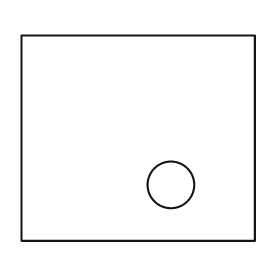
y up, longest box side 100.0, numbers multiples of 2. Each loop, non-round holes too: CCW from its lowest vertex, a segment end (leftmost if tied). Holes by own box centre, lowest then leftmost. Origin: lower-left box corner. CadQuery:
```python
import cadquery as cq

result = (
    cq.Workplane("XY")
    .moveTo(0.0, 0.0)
    .lineTo(100.0, 0.0)
    .lineTo(100.0, 88.0)
    .lineTo(0.0, 88.0)
    .close()
    .moveTo(64.0, 24.0)
    .circle(10.0)
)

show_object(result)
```